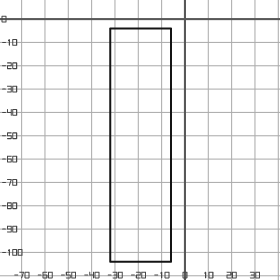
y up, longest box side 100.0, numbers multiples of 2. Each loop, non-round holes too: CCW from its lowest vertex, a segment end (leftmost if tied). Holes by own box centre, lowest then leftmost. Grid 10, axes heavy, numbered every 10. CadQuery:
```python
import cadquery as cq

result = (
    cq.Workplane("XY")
    .moveTo(-32.0, -104.0)
    .lineTo(-6.0, -104.0)
    .lineTo(-6.0, -4.0)
    .lineTo(-32.0, -4.0)
    .close()
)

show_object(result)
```